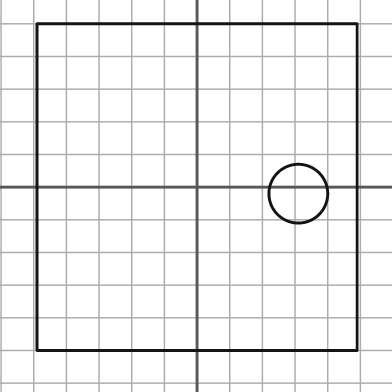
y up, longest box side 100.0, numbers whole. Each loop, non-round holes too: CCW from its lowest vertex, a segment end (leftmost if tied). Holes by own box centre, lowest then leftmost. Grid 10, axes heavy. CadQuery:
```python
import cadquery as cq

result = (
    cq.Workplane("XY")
    .moveTo(-49.0, -50.0)
    .lineTo(49.0, -50.0)
    .lineTo(49.0, 50.0)
    .lineTo(-49.0, 50.0)
    .close()
    .moveTo(31.0, -2.0)
    .circle(9.0)
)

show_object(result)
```